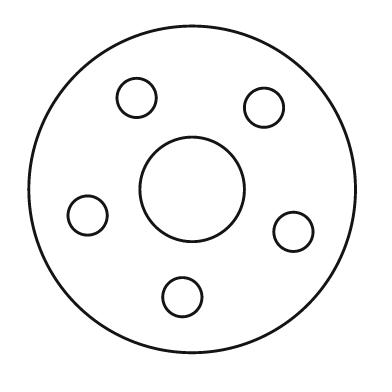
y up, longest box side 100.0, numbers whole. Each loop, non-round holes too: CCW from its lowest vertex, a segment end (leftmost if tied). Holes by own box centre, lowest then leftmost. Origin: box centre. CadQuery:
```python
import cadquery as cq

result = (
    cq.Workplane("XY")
    .moveTo(0.0, 0.0)
    .circle(50.0)
    .moveTo(-3.0, -33.0)
    .circle(6.0)
    .moveTo(31.0, -13.0)
    .circle(6.0)
    .moveTo(-32.0, -8.0)
    .circle(6.0)
    .moveTo(0.0, 0.0)
    .circle(16.0)
    .moveTo(22.0, 25.0)
    .circle(6.0)
    .moveTo(-17.0, 28.0)
    .circle(6.0)
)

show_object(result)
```